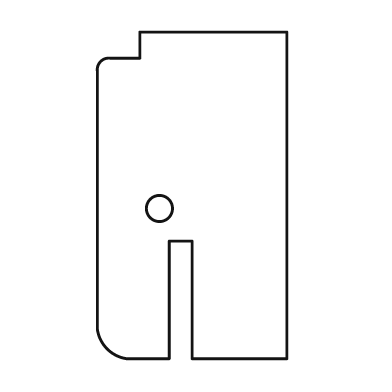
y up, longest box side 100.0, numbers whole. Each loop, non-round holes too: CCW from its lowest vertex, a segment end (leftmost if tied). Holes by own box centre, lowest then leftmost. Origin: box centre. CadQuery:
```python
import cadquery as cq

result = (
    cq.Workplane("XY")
    .moveTo(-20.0, -50.0)
    .lineTo(-7.0, -50.0)
    .lineTo(-7.0, -14.0)
    .lineTo(0.0, -14.0)
    .lineTo(0.0, -50.0)
    .lineTo(29.0, -50.0)
    .lineTo(29.0, 50.0)
    .lineTo(-16.0, 50.0)
    .lineTo(-16.0, 42.0)
    .lineTo(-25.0, 42.0)
    .threePointArc((-28.0, 41.0), (-29.0, 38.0))
    .lineTo(-29.0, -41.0)
    .threePointArc((-26.0, -47.0), (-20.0, -50.0))
    .close()
    .moveTo(-10.0, -4.0)
    .circle(4.0)
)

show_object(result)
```